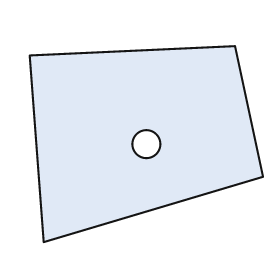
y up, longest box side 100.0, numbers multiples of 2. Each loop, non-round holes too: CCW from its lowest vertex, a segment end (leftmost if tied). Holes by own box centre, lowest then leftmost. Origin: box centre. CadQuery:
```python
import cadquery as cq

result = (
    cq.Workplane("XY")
    .moveTo(-44.0, -42.0)
    .lineTo(50.0, -14.0)
    .lineTo(38.0, 42.0)
    .lineTo(-50.0, 38.0)
    .close()
    .moveTo(0.0, 0.0)
    .circle(6.0)
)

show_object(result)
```